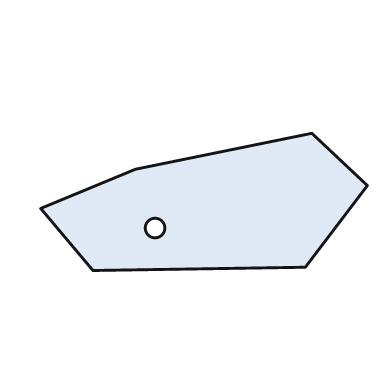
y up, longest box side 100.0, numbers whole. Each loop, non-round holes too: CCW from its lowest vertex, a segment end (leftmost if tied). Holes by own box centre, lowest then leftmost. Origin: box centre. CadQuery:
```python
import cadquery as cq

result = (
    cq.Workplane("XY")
    .moveTo(-34.0, -21.0)
    .lineTo(31.0, -20.0)
    .lineTo(50.0, 5.0)
    .lineTo(33.0, 21.0)
    .lineTo(-21.0, 10.0)
    .lineTo(-50.0, -2.0)
    .close()
    .moveTo(-15.0, -8.0)
    .circle(3.0)
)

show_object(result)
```